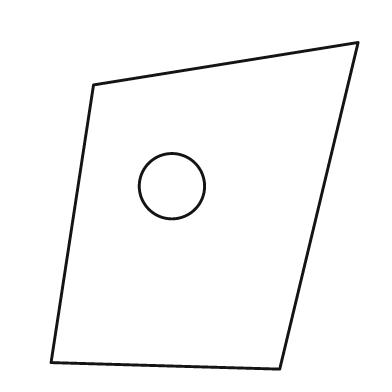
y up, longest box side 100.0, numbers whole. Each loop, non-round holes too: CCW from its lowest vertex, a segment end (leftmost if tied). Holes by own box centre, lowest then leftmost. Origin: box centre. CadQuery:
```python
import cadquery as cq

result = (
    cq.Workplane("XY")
    .moveTo(23.0, -50.0)
    .lineTo(47.0, 50.0)
    .lineTo(-34.0, 37.0)
    .lineTo(-47.0, -48.0)
    .close()
    .moveTo(-10.0, 6.0)
    .circle(10.0)
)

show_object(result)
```